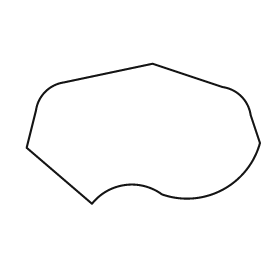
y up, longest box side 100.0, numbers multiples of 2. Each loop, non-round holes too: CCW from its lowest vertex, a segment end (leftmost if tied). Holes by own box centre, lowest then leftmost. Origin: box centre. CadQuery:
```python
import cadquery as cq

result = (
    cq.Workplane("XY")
    .moveTo(-22.0, -30.0)
    .threePointArc((-8.0, -22.0), (8.0, -26.0))
    .threePointArc((34.0, -24.0), (50.0, -4.0))
    .lineTo(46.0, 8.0)
    .threePointArc((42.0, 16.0), (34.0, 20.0))
    .lineTo(4.0, 30.0)
    .lineTo(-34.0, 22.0)
    .threePointArc((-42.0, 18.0), (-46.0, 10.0))
    .lineTo(-50.0, -6.0)
    .close()
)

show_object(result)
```